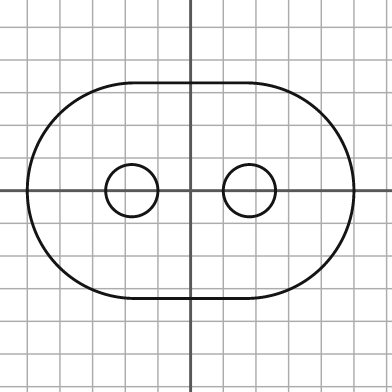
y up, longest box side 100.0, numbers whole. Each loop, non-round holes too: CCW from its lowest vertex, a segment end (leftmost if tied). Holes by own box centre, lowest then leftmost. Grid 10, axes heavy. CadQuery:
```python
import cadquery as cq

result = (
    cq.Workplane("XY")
    .moveTo(-17.0, -33.0)
    .lineTo(17.0, -33.0)
    .threePointArc((50.0, 0.0), (17.0, 33.0))
    .lineTo(-17.0, 33.0)
    .threePointArc((-50.0, 0.0), (-17.0, -33.0))
    .close()
    .moveTo(-18.0, 0.0)
    .circle(8.0)
    .moveTo(18.0, 0.0)
    .circle(8.0)
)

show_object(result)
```